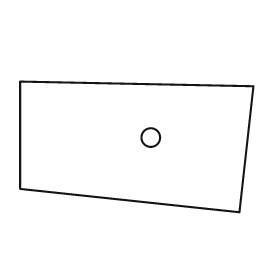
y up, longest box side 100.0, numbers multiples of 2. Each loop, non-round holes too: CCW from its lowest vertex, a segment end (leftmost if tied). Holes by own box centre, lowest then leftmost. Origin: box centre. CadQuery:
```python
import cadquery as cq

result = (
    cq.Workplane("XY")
    .moveTo(44.0, -28.0)
    .lineTo(50.0, 26.0)
    .lineTo(-50.0, 28.0)
    .lineTo(-50.0, -18.0)
    .close()
    .moveTo(6.0, 4.0)
    .circle(4.0)
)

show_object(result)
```